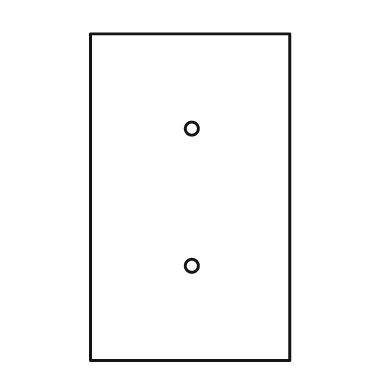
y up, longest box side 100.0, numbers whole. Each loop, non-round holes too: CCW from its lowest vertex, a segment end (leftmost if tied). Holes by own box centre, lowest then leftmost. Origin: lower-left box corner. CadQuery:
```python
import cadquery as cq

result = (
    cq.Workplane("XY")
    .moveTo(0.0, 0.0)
    .lineTo(61.0, 0.0)
    .lineTo(61.0, 100.0)
    .lineTo(0.0, 100.0)
    .close()
    .moveTo(31.0, 29.0)
    .circle(2.0)
    .moveTo(31.0, 71.0)
    .circle(2.0)
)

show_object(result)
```